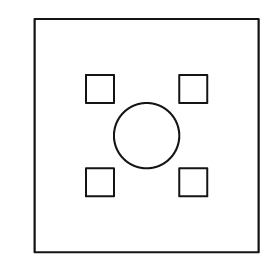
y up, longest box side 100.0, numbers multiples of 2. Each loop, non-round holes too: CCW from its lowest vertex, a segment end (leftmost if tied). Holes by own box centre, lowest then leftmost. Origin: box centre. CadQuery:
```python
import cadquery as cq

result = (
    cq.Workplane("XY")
    .moveTo(-48.0, -50.0)
    .lineTo(48.0, -50.0)
    .lineTo(48.0, 50.0)
    .lineTo(-48.0, 50.0)
    .close()
    .moveTo(-26.0, -26.0)
    .lineTo(-14.0, -26.0)
    .lineTo(-14.0, -14.0)
    .lineTo(-26.0, -14.0)
    .close()
    .moveTo(14.0, -26.0)
    .lineTo(26.0, -26.0)
    .lineTo(26.0, -14.0)
    .lineTo(14.0, -14.0)
    .close()
    .moveTo(0.0, 0.0)
    .circle(14.0)
    .moveTo(-26.0, 14.0)
    .lineTo(-14.0, 14.0)
    .lineTo(-14.0, 26.0)
    .lineTo(-26.0, 26.0)
    .close()
    .moveTo(14.0, 14.0)
    .lineTo(26.0, 14.0)
    .lineTo(26.0, 26.0)
    .lineTo(14.0, 26.0)
    .close()
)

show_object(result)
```